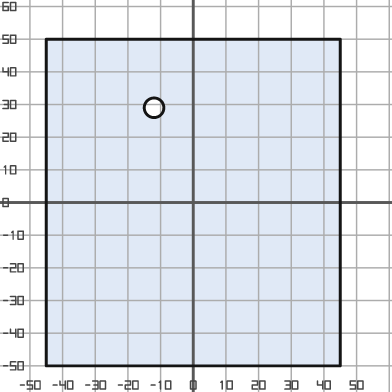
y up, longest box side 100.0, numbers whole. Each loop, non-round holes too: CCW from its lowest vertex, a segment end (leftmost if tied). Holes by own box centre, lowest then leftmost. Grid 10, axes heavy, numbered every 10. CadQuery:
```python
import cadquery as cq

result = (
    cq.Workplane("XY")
    .moveTo(-45.0, -50.0)
    .lineTo(45.0, -50.0)
    .lineTo(45.0, 50.0)
    .lineTo(-45.0, 50.0)
    .close()
    .moveTo(-12.0, 29.0)
    .circle(3.0)
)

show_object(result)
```